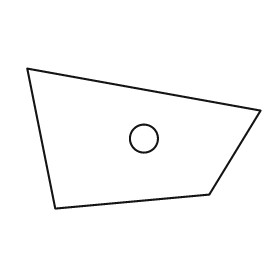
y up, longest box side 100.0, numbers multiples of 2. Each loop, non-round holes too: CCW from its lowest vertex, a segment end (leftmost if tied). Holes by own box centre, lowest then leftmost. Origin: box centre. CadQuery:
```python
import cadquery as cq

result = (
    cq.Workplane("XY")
    .moveTo(-38.0, -30.0)
    .lineTo(28.0, -24.0)
    .lineTo(50.0, 12.0)
    .lineTo(-50.0, 30.0)
    .close()
    .moveTo(0.0, 0.0)
    .circle(6.0)
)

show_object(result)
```